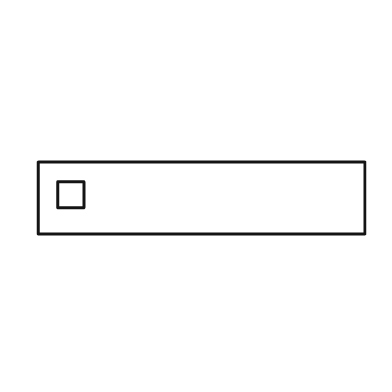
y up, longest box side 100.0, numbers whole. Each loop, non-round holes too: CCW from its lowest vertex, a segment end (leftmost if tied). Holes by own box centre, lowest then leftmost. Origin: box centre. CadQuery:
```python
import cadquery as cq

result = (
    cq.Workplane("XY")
    .moveTo(-50.0, -11.0)
    .lineTo(50.0, -11.0)
    .lineTo(50.0, 11.0)
    .lineTo(-50.0, 11.0)
    .close()
    .moveTo(-44.0, -3.0)
    .lineTo(-36.0, -3.0)
    .lineTo(-36.0, 5.0)
    .lineTo(-44.0, 5.0)
    .close()
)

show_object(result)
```